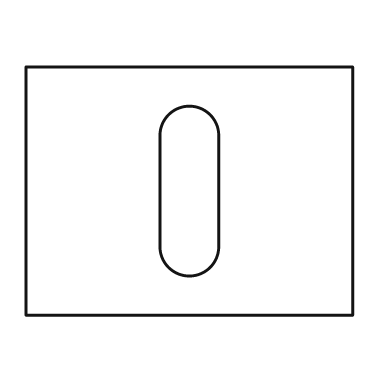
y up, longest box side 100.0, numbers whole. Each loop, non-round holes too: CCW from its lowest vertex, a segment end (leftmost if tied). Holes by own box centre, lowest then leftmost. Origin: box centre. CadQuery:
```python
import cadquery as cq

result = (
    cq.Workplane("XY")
    .moveTo(-50.0, -38.0)
    .lineTo(50.0, -38.0)
    .lineTo(50.0, 38.0)
    .lineTo(-50.0, 38.0)
    .close()
    .moveTo(-9.0, -17.0)
    .threePointArc((0.0, -26.0), (9.0, -17.0))
    .lineTo(9.0, 17.0)
    .threePointArc((0.0, 26.0), (-9.0, 17.0))
    .close()
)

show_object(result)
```